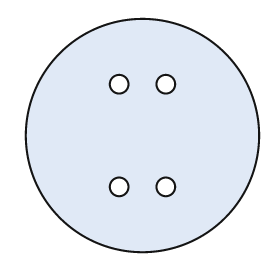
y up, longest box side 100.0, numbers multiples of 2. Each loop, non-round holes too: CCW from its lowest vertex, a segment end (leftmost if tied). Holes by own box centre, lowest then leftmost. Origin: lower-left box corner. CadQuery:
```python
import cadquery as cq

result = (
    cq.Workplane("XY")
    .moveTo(50.0, 50.0)
    .circle(50.0)
    .moveTo(40.0, 28.0)
    .circle(4.0)
    .moveTo(60.0, 28.0)
    .circle(4.0)
    .moveTo(40.0, 72.0)
    .circle(4.0)
    .moveTo(60.0, 72.0)
    .circle(4.0)
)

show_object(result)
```